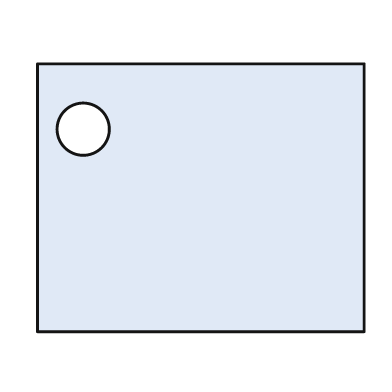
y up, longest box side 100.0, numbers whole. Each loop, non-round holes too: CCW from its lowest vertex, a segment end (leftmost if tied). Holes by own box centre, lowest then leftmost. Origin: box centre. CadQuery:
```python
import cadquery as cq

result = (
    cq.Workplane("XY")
    .moveTo(-50.0, -41.0)
    .lineTo(50.0, -41.0)
    .lineTo(50.0, 41.0)
    .lineTo(-50.0, 41.0)
    .close()
    .moveTo(-36.0, 21.0)
    .circle(8.0)
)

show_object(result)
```